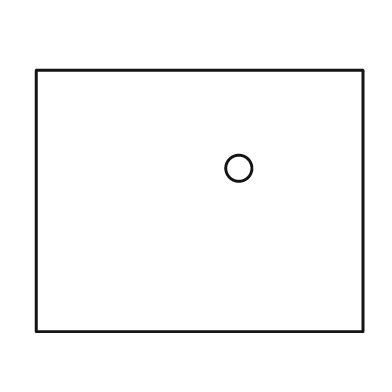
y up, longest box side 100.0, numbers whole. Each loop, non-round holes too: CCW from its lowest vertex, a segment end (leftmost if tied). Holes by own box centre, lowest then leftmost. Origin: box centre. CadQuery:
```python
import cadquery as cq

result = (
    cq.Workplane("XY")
    .moveTo(-50.0, -40.0)
    .lineTo(50.0, -40.0)
    .lineTo(50.0, 40.0)
    .lineTo(-50.0, 40.0)
    .close()
    .moveTo(12.0, 10.0)
    .circle(4.0)
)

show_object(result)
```